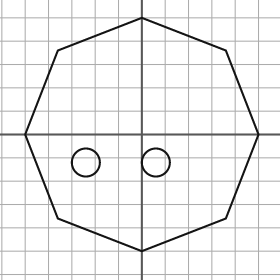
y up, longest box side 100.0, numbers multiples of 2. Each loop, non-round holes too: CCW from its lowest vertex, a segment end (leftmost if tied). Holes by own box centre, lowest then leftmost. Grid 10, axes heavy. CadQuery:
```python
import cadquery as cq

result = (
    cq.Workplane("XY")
    .moveTo(0.0, -50.0)
    .lineTo(36.0, -36.0)
    .lineTo(50.0, 0.0)
    .lineTo(36.0, 36.0)
    .lineTo(0.0, 50.0)
    .lineTo(-36.0, 36.0)
    .lineTo(-50.0, 0.0)
    .lineTo(-36.0, -36.0)
    .close()
    .moveTo(-24.0, -12.0)
    .circle(6.0)
    .moveTo(6.0, -12.0)
    .circle(6.0)
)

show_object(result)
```